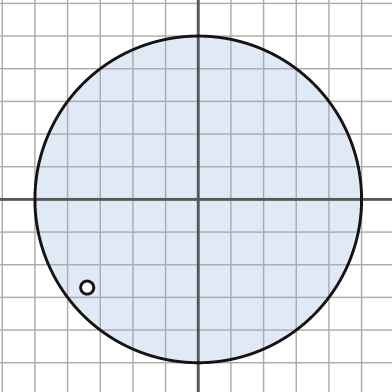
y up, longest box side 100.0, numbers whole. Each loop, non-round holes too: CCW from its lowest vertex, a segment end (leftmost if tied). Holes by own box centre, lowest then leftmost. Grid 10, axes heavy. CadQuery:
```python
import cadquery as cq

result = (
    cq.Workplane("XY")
    .moveTo(0.0, 0.0)
    .circle(50.0)
    .moveTo(-34.0, -27.0)
    .circle(2.0)
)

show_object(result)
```